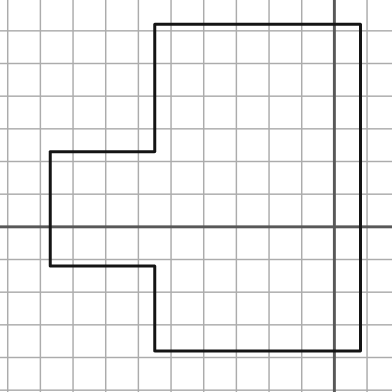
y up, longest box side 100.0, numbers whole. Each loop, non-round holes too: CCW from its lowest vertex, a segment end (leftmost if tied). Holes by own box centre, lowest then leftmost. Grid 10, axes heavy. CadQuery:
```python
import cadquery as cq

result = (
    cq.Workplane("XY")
    .moveTo(-55.0, -38.0)
    .lineTo(8.0, -38.0)
    .lineTo(8.0, 62.0)
    .lineTo(-55.0, 62.0)
    .lineTo(-55.0, 23.0)
    .lineTo(-87.0, 23.0)
    .lineTo(-87.0, -12.0)
    .lineTo(-55.0, -12.0)
    .close()
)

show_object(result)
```